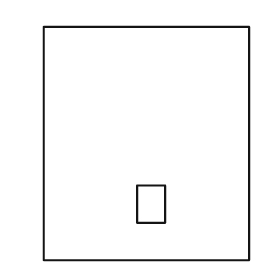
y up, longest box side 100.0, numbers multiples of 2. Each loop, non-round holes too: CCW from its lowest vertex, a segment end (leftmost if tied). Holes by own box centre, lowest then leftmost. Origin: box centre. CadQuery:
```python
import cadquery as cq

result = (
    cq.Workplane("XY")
    .moveTo(-44.0, -50.0)
    .lineTo(44.0, -50.0)
    .lineTo(44.0, 50.0)
    .lineTo(-44.0, 50.0)
    .close()
    .moveTo(-4.0, -34.0)
    .lineTo(8.0, -34.0)
    .lineTo(8.0, -18.0)
    .lineTo(-4.0, -18.0)
    .close()
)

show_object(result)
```